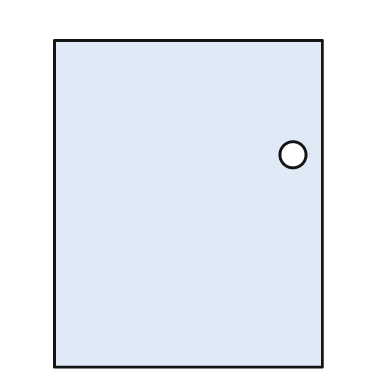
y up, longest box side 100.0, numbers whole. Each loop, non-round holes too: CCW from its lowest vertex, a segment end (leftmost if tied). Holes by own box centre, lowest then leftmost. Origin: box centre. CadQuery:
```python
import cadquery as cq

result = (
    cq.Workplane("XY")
    .moveTo(-41.0, -50.0)
    .lineTo(41.0, -50.0)
    .lineTo(41.0, 50.0)
    .lineTo(-41.0, 50.0)
    .close()
    .moveTo(32.0, 15.0)
    .circle(4.0)
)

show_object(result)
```